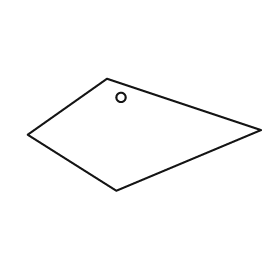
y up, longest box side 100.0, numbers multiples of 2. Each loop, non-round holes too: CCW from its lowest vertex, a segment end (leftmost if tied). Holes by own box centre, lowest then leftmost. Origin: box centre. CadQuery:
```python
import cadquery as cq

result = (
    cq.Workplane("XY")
    .moveTo(-12.0, -24.0)
    .lineTo(50.0, 2.0)
    .lineTo(-16.0, 24.0)
    .lineTo(-50.0, 0.0)
    .close()
    .moveTo(-10.0, 16.0)
    .circle(2.0)
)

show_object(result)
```